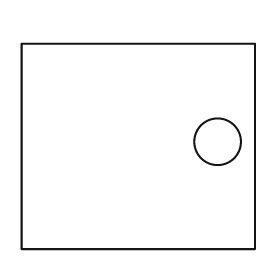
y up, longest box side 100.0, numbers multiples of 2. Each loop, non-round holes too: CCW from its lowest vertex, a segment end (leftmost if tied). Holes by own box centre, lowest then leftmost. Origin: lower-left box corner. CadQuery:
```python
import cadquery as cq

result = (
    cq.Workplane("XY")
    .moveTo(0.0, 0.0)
    .lineTo(100.0, 0.0)
    .lineTo(100.0, 88.0)
    .lineTo(0.0, 88.0)
    .close()
    .moveTo(84.0, 46.0)
    .circle(10.0)
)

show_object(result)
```